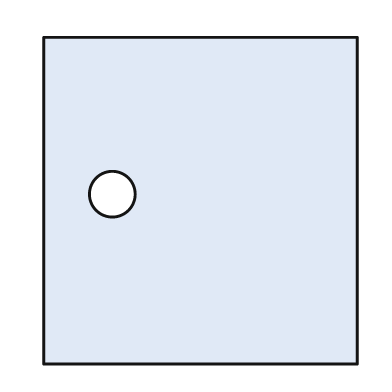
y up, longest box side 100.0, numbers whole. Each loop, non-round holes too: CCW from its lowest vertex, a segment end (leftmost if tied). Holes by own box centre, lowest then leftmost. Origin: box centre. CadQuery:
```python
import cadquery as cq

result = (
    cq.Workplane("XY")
    .moveTo(-48.0, -50.0)
    .lineTo(48.0, -50.0)
    .lineTo(48.0, 50.0)
    .lineTo(-48.0, 50.0)
    .close()
    .moveTo(-27.0, 2.0)
    .circle(7.0)
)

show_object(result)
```